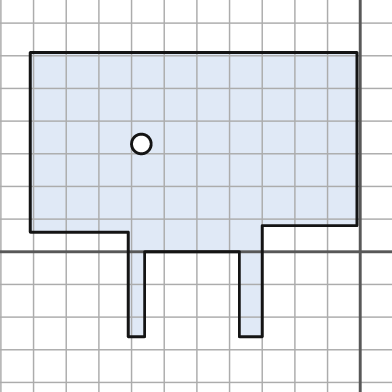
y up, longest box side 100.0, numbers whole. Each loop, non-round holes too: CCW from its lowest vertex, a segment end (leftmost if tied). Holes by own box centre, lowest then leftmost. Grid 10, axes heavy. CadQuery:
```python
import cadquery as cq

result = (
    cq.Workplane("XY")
    .moveTo(-71.0, -26.0)
    .lineTo(-66.0, -26.0)
    .lineTo(-66.0, 0.0)
    .lineTo(-37.0, 0.0)
    .lineTo(-37.0, -26.0)
    .lineTo(-30.0, -26.0)
    .lineTo(-30.0, 8.0)
    .lineTo(-1.0, 8.0)
    .lineTo(-1.0, 61.0)
    .lineTo(-101.0, 61.0)
    .lineTo(-101.0, 6.0)
    .lineTo(-71.0, 6.0)
    .close()
    .moveTo(-67.0, 33.0)
    .circle(3.0)
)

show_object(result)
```